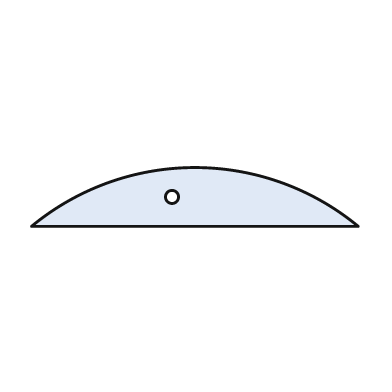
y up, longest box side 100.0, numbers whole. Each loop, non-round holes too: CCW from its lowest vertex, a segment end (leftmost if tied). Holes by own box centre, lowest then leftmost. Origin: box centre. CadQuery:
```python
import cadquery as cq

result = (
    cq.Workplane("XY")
    .moveTo(-50.0, -9.0)
    .lineTo(50.0, -9.0)
    .threePointArc((0.0, 9.0), (-50.0, -9.0))
    .close()
    .moveTo(-7.0, 0.0)
    .circle(2.0)
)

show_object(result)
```